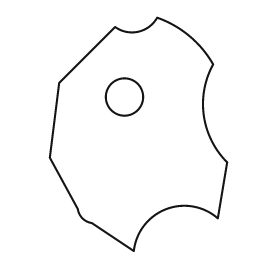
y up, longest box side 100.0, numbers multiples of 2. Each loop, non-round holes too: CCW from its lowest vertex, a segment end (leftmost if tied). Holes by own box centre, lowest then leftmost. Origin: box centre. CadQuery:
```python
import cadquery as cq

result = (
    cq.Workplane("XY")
    .moveTo(-2.0, -50.0)
    .threePointArc((12.0, -32.0), (34.0, -36.0))
    .lineTo(38.0, -12.0)
    .threePointArc((28.0, 8.0), (32.0, 30.0))
    .threePointArc((22.0, 42.0), (8.0, 50.0))
    .threePointArc((0.0, 44.0), (-10.0, 46.0))
    .lineTo(-34.0, 22.0)
    .lineTo(-38.0, -10.0)
    .lineTo(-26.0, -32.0)
    .threePointArc((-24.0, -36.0), (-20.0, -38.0))
    .close()
    .moveTo(-6.0, 16.0)
    .circle(8.0)
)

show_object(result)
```